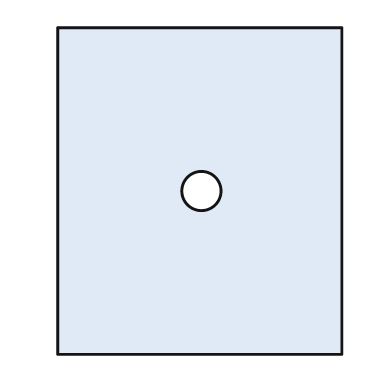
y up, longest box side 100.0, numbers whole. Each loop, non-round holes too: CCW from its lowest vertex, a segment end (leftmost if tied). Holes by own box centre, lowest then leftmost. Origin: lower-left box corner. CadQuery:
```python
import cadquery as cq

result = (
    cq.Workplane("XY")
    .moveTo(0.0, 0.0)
    .lineTo(87.0, 0.0)
    .lineTo(87.0, 100.0)
    .lineTo(0.0, 100.0)
    .close()
    .moveTo(44.0, 50.0)
    .circle(6.0)
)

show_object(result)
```